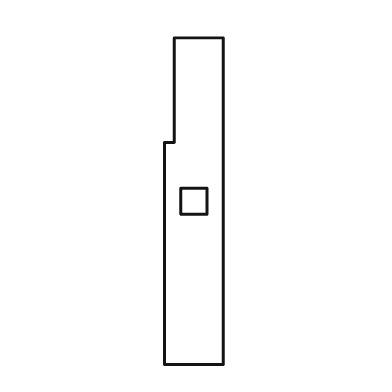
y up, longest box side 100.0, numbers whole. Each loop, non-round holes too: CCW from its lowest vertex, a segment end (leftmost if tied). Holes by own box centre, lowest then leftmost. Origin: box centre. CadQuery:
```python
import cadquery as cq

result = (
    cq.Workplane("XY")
    .moveTo(-9.0, -50.0)
    .lineTo(9.0, -50.0)
    .lineTo(9.0, 50.0)
    .lineTo(-6.0, 50.0)
    .lineTo(-6.0, 18.0)
    .lineTo(-9.0, 18.0)
    .close()
    .moveTo(-4.0, -4.0)
    .lineTo(4.0, -4.0)
    .lineTo(4.0, 4.0)
    .lineTo(-4.0, 4.0)
    .close()
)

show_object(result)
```